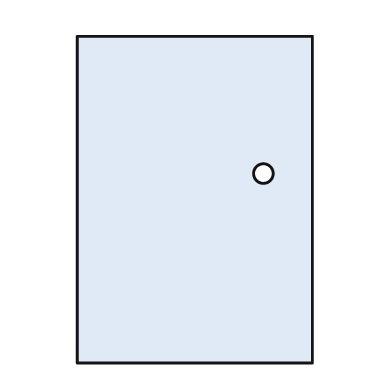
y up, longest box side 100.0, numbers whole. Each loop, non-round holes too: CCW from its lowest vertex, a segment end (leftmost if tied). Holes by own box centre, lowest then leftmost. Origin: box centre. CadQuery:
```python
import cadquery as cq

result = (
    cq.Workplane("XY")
    .moveTo(-36.0, -50.0)
    .lineTo(36.0, -50.0)
    .lineTo(36.0, 50.0)
    .lineTo(-36.0, 50.0)
    .close()
    .moveTo(21.0, 8.0)
    .circle(3.0)
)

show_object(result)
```